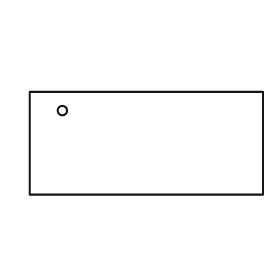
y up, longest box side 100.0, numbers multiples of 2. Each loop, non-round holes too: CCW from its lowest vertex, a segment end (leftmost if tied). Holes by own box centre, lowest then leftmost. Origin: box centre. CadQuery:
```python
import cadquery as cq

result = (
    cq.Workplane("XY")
    .moveTo(-50.0, -22.0)
    .lineTo(50.0, -22.0)
    .lineTo(50.0, 22.0)
    .lineTo(-50.0, 22.0)
    .close()
    .moveTo(-36.0, 14.0)
    .circle(2.0)
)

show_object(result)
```